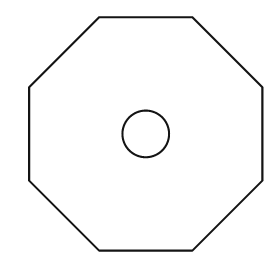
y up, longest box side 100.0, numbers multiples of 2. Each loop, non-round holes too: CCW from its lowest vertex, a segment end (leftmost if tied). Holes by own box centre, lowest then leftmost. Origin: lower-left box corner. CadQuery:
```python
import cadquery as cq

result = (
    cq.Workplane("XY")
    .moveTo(30.0, 0.0)
    .lineTo(70.0, 0.0)
    .lineTo(100.0, 30.0)
    .lineTo(100.0, 70.0)
    .lineTo(70.0, 100.0)
    .lineTo(30.0, 100.0)
    .lineTo(0.0, 70.0)
    .lineTo(0.0, 30.0)
    .close()
    .moveTo(50.0, 50.0)
    .circle(10.0)
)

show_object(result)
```